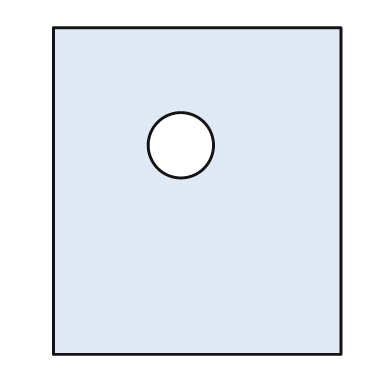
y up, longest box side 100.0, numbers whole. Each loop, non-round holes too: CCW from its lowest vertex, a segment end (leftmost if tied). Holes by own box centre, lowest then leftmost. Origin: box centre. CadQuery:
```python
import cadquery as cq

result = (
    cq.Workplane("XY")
    .moveTo(-44.0, -50.0)
    .lineTo(44.0, -50.0)
    .lineTo(44.0, 50.0)
    .lineTo(-44.0, 50.0)
    .close()
    .moveTo(-5.0, 14.0)
    .circle(10.0)
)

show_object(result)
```